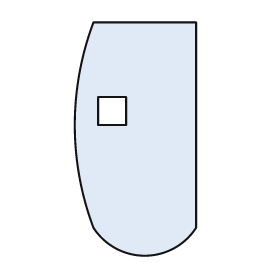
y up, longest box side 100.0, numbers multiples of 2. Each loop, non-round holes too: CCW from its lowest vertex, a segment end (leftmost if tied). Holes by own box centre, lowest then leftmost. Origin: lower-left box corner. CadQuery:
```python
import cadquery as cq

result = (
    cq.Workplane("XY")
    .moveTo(8.0, 12.0)
    .threePointArc((30.0, 0.0), (52.0, 12.0))
    .lineTo(52.0, 100.0)
    .lineTo(8.0, 100.0)
    .threePointArc((0.0, 56.0), (8.0, 12.0))
    .close()
    .moveTo(10.0, 56.0)
    .lineTo(22.0, 56.0)
    .lineTo(22.0, 68.0)
    .lineTo(10.0, 68.0)
    .close()
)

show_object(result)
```